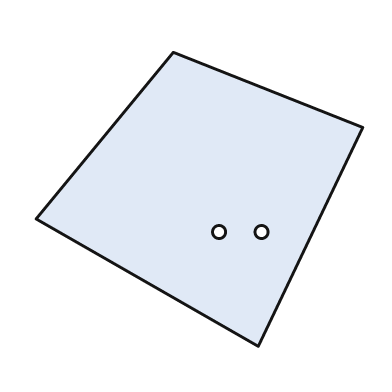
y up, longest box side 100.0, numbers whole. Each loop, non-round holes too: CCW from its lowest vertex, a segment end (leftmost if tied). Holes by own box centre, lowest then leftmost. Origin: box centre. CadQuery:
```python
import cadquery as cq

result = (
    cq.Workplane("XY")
    .moveTo(18.0, -45.0)
    .lineTo(50.0, 22.0)
    .lineTo(-8.0, 45.0)
    .lineTo(-50.0, -6.0)
    .close()
    .moveTo(6.0, -10.0)
    .circle(2.0)
    .moveTo(19.0, -10.0)
    .circle(2.0)
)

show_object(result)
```